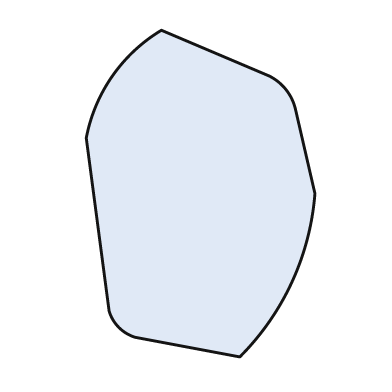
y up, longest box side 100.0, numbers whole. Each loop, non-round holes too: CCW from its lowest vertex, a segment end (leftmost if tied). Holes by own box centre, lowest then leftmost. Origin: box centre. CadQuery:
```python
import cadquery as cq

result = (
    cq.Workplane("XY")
    .moveTo(12.0, -50.0)
    .threePointArc((28.0, -27.0), (35.0, 0.0))
    .lineTo(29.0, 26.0)
    .threePointArc((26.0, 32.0), (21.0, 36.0))
    .lineTo(-12.0, 50.0)
    .threePointArc((-27.0, 36.0), (-35.0, 17.0))
    .lineTo(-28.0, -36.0)
    .threePointArc((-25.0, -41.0), (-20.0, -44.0))
    .close()
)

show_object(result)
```